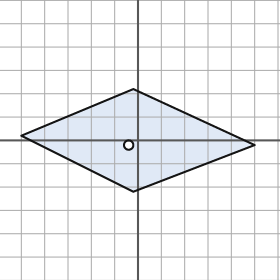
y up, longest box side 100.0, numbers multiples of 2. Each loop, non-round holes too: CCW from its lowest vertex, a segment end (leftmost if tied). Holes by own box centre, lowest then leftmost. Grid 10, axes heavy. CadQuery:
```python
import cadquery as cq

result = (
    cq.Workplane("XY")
    .moveTo(-2.0, -22.0)
    .lineTo(50.0, -2.0)
    .lineTo(-2.0, 22.0)
    .lineTo(-50.0, 2.0)
    .close()
    .moveTo(-4.0, -2.0)
    .circle(2.0)
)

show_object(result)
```